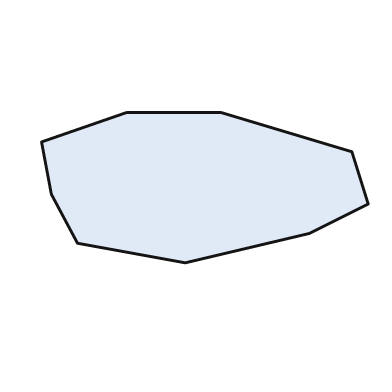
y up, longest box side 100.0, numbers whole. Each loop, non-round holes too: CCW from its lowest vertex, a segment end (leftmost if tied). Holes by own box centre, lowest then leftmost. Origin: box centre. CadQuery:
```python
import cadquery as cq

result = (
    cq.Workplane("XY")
    .moveTo(-6.0, -23.0)
    .lineTo(32.0, -14.0)
    .lineTo(50.0, -5.0)
    .lineTo(45.0, 11.0)
    .lineTo(5.0, 23.0)
    .lineTo(-24.0, 23.0)
    .lineTo(-50.0, 14.0)
    .lineTo(-47.0, -2.0)
    .lineTo(-39.0, -17.0)
    .close()
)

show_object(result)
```